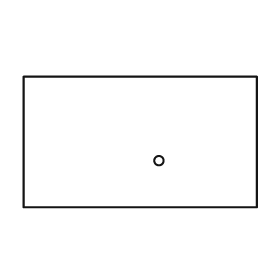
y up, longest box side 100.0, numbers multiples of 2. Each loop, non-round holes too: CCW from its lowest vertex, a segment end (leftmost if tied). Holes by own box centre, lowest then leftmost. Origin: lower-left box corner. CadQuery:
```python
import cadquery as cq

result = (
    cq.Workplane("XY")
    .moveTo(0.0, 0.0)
    .lineTo(100.0, 0.0)
    .lineTo(100.0, 56.0)
    .lineTo(0.0, 56.0)
    .close()
    .moveTo(58.0, 20.0)
    .circle(2.0)
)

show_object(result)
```